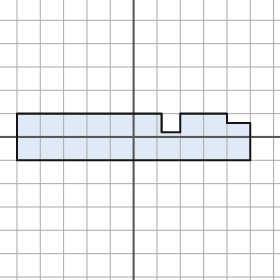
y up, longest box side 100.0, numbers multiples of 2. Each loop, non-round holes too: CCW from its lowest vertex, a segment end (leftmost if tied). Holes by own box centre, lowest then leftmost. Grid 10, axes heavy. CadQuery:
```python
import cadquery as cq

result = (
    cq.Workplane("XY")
    .moveTo(-50.0, -10.0)
    .lineTo(50.0, -10.0)
    .lineTo(50.0, 6.0)
    .lineTo(40.0, 6.0)
    .lineTo(40.0, 10.0)
    .lineTo(20.0, 10.0)
    .lineTo(20.0, 2.0)
    .lineTo(12.0, 2.0)
    .lineTo(12.0, 10.0)
    .lineTo(-50.0, 10.0)
    .close()
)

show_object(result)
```